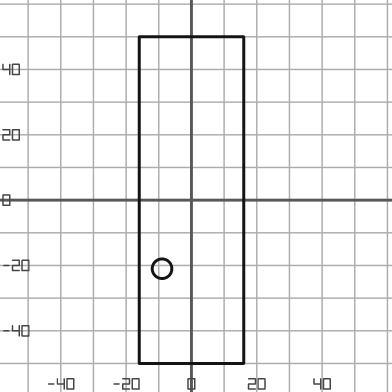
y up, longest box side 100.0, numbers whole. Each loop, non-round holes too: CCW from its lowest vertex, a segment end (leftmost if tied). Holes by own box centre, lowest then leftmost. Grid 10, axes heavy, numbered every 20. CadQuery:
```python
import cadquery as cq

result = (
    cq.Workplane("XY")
    .moveTo(-16.0, -50.0)
    .lineTo(16.0, -50.0)
    .lineTo(16.0, 50.0)
    .lineTo(-16.0, 50.0)
    .close()
    .moveTo(-9.0, -21.0)
    .circle(3.0)
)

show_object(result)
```